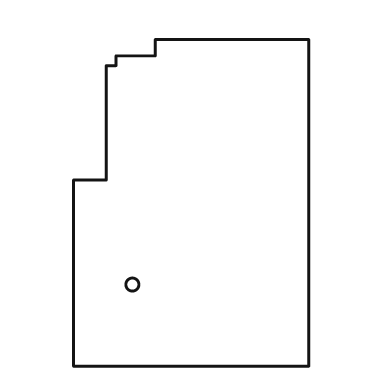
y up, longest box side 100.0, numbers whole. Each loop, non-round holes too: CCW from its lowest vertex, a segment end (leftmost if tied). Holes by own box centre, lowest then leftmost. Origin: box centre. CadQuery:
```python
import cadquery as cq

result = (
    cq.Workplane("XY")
    .moveTo(-36.0, -50.0)
    .lineTo(36.0, -50.0)
    .lineTo(36.0, 50.0)
    .lineTo(-11.0, 50.0)
    .lineTo(-11.0, 45.0)
    .lineTo(-23.0, 45.0)
    .lineTo(-23.0, 42.0)
    .lineTo(-26.0, 42.0)
    .lineTo(-26.0, 7.0)
    .lineTo(-36.0, 7.0)
    .close()
    .moveTo(-18.0, -25.0)
    .circle(2.0)
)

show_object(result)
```